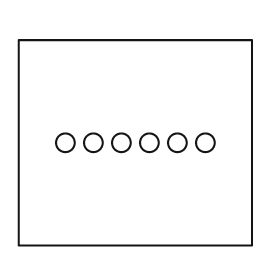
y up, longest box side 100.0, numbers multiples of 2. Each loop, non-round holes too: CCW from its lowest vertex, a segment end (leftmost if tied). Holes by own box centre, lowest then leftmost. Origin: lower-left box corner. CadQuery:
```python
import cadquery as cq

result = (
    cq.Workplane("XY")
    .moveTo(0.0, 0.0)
    .lineTo(100.0, 0.0)
    .lineTo(100.0, 88.0)
    .lineTo(0.0, 88.0)
    .close()
    .moveTo(20.0, 44.0)
    .circle(4.0)
    .moveTo(32.0, 44.0)
    .circle(4.0)
    .moveTo(44.0, 44.0)
    .circle(4.0)
    .moveTo(56.0, 44.0)
    .circle(4.0)
    .moveTo(68.0, 44.0)
    .circle(4.0)
    .moveTo(80.0, 44.0)
    .circle(4.0)
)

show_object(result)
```